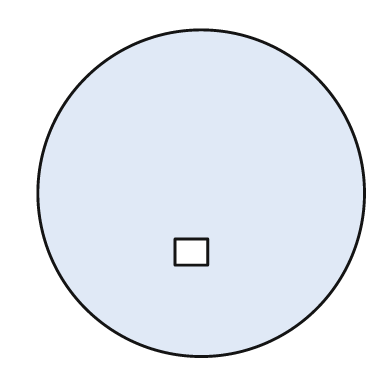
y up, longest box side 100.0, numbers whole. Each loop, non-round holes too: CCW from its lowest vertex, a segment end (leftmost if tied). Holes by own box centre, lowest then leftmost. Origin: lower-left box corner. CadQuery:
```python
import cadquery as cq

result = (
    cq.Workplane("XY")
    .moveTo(50.0, 50.0)
    .circle(50.0)
    .moveTo(42.0, 28.0)
    .lineTo(52.0, 28.0)
    .lineTo(52.0, 36.0)
    .lineTo(42.0, 36.0)
    .close()
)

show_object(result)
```